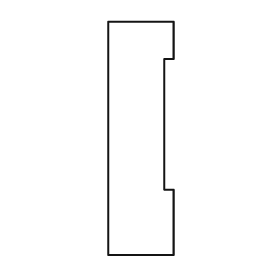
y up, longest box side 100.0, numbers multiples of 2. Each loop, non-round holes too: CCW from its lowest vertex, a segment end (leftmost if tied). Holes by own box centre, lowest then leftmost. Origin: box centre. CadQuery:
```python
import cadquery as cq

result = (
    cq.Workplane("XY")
    .moveTo(-14.0, -50.0)
    .lineTo(14.0, -50.0)
    .lineTo(14.0, -22.0)
    .lineTo(10.0, -22.0)
    .lineTo(10.0, 34.0)
    .lineTo(14.0, 34.0)
    .lineTo(14.0, 50.0)
    .lineTo(-14.0, 50.0)
    .close()
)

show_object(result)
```